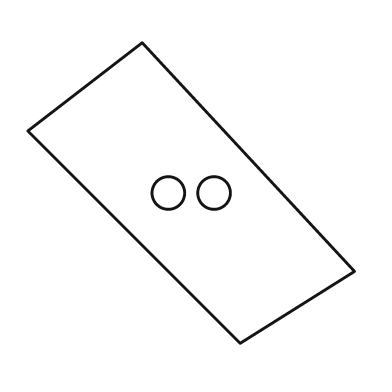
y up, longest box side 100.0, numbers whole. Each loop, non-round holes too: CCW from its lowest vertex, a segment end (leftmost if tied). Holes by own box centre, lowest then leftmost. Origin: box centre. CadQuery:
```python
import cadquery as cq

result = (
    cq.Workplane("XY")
    .moveTo(15.0, -46.0)
    .lineTo(50.0, -24.0)
    .lineTo(-15.0, 46.0)
    .lineTo(-50.0, 19.0)
    .close()
    .moveTo(-7.0, 0.0)
    .circle(5.0)
    .moveTo(7.0, 0.0)
    .circle(5.0)
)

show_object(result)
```